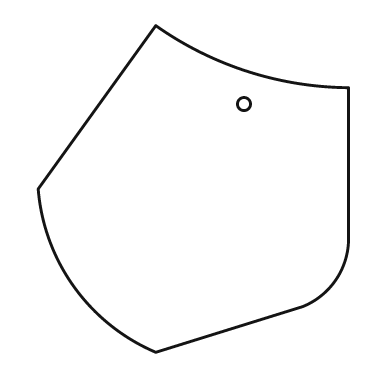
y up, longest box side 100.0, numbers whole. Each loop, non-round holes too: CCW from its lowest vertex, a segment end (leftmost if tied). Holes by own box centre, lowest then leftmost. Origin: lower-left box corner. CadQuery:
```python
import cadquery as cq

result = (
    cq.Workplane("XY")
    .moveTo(36.0, 0.0)
    .lineTo(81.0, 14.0)
    .threePointArc((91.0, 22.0), (95.0, 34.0))
    .lineTo(95.0, 81.0)
    .threePointArc((64.0, 86.0), (36.0, 100.0))
    .lineTo(0.0, 50.0)
    .threePointArc((11.0, 20.0), (36.0, 0.0))
    .close()
    .moveTo(63.0, 76.0)
    .circle(2.0)
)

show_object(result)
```